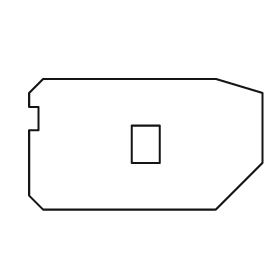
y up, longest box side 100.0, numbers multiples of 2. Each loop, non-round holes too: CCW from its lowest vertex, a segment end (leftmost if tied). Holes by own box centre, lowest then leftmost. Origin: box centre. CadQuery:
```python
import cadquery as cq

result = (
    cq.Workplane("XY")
    .moveTo(-44.0, -28.0)
    .lineTo(30.0, -28.0)
    .lineTo(50.0, -8.0)
    .lineTo(50.0, 22.0)
    .lineTo(30.0, 28.0)
    .lineTo(-44.0, 28.0)
    .lineTo(-50.0, 22.0)
    .lineTo(-50.0, 16.0)
    .lineTo(-46.0, 16.0)
    .lineTo(-46.0, 6.0)
    .lineTo(-50.0, 6.0)
    .lineTo(-50.0, -22.0)
    .close()
    .moveTo(-6.0, -8.0)
    .lineTo(6.0, -8.0)
    .lineTo(6.0, 8.0)
    .lineTo(-6.0, 8.0)
    .close()
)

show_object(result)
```